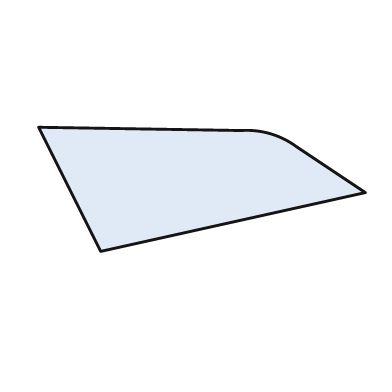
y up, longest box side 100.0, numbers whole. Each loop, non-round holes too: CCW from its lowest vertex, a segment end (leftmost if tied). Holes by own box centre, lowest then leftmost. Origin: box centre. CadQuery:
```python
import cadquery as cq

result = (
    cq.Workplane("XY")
    .moveTo(-31.0, -19.0)
    .lineTo(50.0, -1.0)
    .lineTo(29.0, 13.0)
    .threePointArc((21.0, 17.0), (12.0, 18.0))
    .lineTo(-50.0, 19.0)
    .close()
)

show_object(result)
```